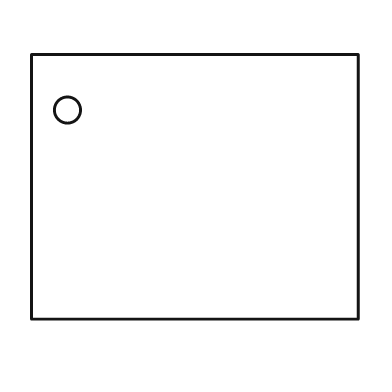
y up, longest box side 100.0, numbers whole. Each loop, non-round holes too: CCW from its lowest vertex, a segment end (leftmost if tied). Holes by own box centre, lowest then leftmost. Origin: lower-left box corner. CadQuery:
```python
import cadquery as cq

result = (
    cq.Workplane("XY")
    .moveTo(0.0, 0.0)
    .lineTo(100.0, 0.0)
    .lineTo(100.0, 81.0)
    .lineTo(0.0, 81.0)
    .close()
    .moveTo(11.0, 64.0)
    .circle(4.0)
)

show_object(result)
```